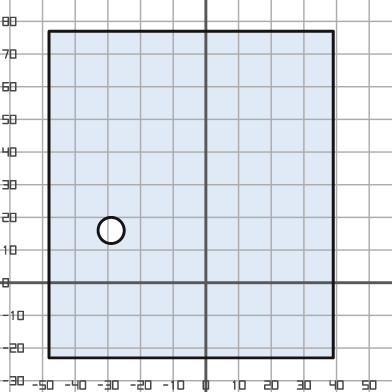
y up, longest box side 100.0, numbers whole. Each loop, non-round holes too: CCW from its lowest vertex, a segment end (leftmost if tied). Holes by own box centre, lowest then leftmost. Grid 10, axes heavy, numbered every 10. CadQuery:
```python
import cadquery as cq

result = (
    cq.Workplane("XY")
    .moveTo(-48.0, -23.0)
    .lineTo(39.0, -23.0)
    .lineTo(39.0, 77.0)
    .lineTo(-48.0, 77.0)
    .close()
    .moveTo(-29.0, 16.0)
    .circle(4.0)
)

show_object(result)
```